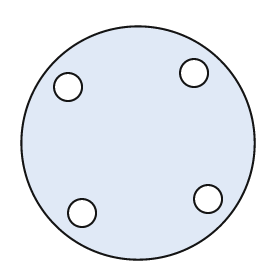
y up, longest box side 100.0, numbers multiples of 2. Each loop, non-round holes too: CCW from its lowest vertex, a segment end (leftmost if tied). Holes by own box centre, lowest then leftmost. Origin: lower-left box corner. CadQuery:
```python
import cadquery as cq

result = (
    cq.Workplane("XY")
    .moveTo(50.0, 50.0)
    .circle(50.0)
    .moveTo(26.0, 20.0)
    .circle(6.0)
    .moveTo(80.0, 26.0)
    .circle(6.0)
    .moveTo(20.0, 74.0)
    .circle(6.0)
    .moveTo(74.0, 80.0)
    .circle(6.0)
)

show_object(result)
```